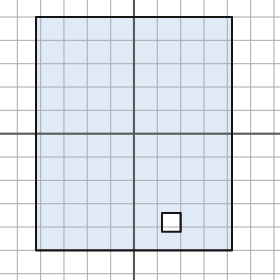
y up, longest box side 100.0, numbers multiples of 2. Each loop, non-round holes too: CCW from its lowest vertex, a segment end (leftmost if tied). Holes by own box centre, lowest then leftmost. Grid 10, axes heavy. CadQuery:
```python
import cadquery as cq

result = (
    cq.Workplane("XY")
    .moveTo(-42.0, -50.0)
    .lineTo(42.0, -50.0)
    .lineTo(42.0, 50.0)
    .lineTo(-42.0, 50.0)
    .close()
    .moveTo(12.0, -42.0)
    .lineTo(20.0, -42.0)
    .lineTo(20.0, -34.0)
    .lineTo(12.0, -34.0)
    .close()
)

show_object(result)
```